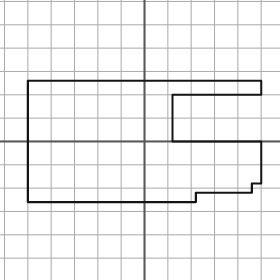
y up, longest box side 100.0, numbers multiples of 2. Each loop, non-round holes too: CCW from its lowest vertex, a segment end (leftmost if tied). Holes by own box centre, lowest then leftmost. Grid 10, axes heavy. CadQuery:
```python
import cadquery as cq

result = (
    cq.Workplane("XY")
    .moveTo(-50.0, -26.0)
    .lineTo(22.0, -26.0)
    .lineTo(22.0, -22.0)
    .lineTo(46.0, -22.0)
    .lineTo(46.0, -18.0)
    .lineTo(50.0, -18.0)
    .lineTo(50.0, 0.0)
    .lineTo(12.0, 0.0)
    .lineTo(12.0, 20.0)
    .lineTo(50.0, 20.0)
    .lineTo(50.0, 26.0)
    .lineTo(-50.0, 26.0)
    .close()
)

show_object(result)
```